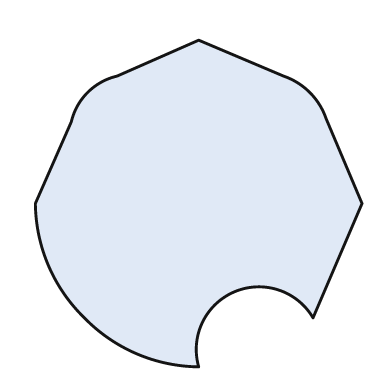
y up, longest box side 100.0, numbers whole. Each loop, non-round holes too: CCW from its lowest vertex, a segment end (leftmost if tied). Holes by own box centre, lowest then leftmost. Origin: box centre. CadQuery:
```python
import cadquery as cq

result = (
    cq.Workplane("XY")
    .moveTo(0.0, -50.0)
    .threePointArc((11.0, -27.0), (35.0, -35.0))
    .lineTo(50.0, 0.0)
    .lineTo(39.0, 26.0)
    .threePointArc((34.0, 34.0), (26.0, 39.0))
    .lineTo(0.0, 50.0)
    .lineTo(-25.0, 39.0)
    .threePointArc((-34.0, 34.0), (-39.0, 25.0))
    .lineTo(-50.0, 0.0)
    .threePointArc((-46.0, -19.0), (-35.0, -35.0))
    .threePointArc((-19.0, -46.0), (0.0, -50.0))
    .close()
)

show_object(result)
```